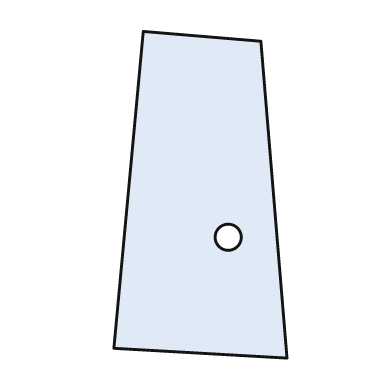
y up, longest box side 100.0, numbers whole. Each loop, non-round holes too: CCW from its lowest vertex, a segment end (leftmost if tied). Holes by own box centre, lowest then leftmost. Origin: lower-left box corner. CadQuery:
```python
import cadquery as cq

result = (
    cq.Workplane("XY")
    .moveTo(53.0, 0.0)
    .lineTo(45.0, 97.0)
    .lineTo(9.0, 100.0)
    .lineTo(0.0, 3.0)
    .close()
    .moveTo(35.0, 37.0)
    .circle(4.0)
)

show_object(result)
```